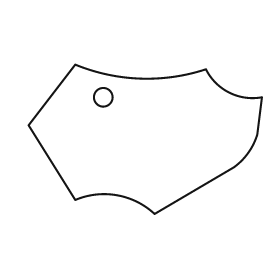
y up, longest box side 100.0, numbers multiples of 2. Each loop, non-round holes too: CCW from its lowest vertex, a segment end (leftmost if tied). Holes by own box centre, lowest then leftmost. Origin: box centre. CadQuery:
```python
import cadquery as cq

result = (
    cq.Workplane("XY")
    .moveTo(4.0, -32.0)
    .lineTo(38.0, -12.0)
    .threePointArc((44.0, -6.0), (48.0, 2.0))
    .lineTo(50.0, 18.0)
    .threePointArc((36.0, 20.0), (26.0, 30.0))
    .threePointArc((-2.0, 26.0), (-30.0, 32.0))
    .lineTo(-50.0, 6.0)
    .lineTo(-30.0, -26.0)
    .threePointArc((-12.0, -24.0), (4.0, -32.0))
    .close()
    .moveTo(-18.0, 18.0)
    .circle(4.0)
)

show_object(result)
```